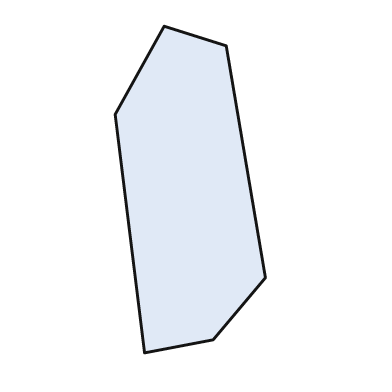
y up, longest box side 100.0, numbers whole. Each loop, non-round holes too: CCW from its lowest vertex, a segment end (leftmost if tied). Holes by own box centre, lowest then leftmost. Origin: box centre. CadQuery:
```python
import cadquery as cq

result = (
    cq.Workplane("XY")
    .moveTo(-14.0, -50.0)
    .lineTo(7.0, -46.0)
    .lineTo(23.0, -27.0)
    .lineTo(11.0, 44.0)
    .lineTo(-8.0, 50.0)
    .lineTo(-23.0, 23.0)
    .close()
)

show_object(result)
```